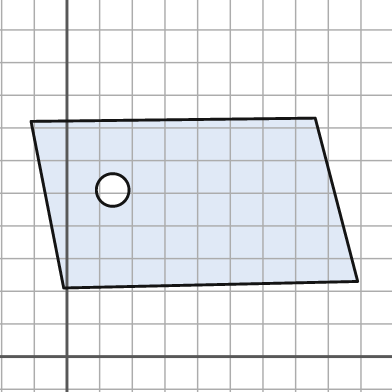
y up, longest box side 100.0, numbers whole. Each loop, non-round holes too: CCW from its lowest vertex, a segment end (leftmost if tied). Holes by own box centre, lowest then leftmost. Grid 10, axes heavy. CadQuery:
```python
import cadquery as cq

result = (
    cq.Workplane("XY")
    .moveTo(-1.0, 21.0)
    .lineTo(89.0, 23.0)
    .lineTo(76.0, 73.0)
    .lineTo(-11.0, 72.0)
    .close()
    .moveTo(14.0, 51.0)
    .circle(5.0)
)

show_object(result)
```